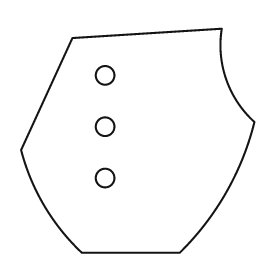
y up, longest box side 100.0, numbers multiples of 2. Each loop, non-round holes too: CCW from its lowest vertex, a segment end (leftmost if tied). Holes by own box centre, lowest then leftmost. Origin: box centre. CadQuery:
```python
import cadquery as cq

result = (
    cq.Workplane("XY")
    .moveTo(-24.0, -48.0)
    .lineTo(18.0, -48.0)
    .threePointArc((38.0, -22.0), (50.0, 8.0))
    .threePointArc((38.0, 26.0), (36.0, 48.0))
    .lineTo(-28.0, 44.0)
    .lineTo(-50.0, -4.0)
    .threePointArc((-40.0, -28.0), (-24.0, -48.0))
    .close()
    .moveTo(-14.0, -16.0)
    .circle(4.0)
    .moveTo(-14.0, 6.0)
    .circle(4.0)
    .moveTo(-14.0, 28.0)
    .circle(4.0)
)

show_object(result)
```